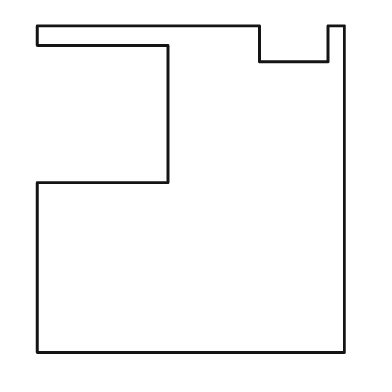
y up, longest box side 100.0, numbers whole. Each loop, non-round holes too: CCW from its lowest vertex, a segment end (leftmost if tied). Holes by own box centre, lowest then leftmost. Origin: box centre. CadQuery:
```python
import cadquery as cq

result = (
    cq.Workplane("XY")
    .moveTo(-47.0, -50.0)
    .lineTo(47.0, -50.0)
    .lineTo(47.0, 50.0)
    .lineTo(42.0, 50.0)
    .lineTo(42.0, 39.0)
    .lineTo(21.0, 39.0)
    .lineTo(21.0, 50.0)
    .lineTo(-47.0, 50.0)
    .lineTo(-47.0, 44.0)
    .lineTo(-7.0, 44.0)
    .lineTo(-7.0, 2.0)
    .lineTo(-47.0, 2.0)
    .close()
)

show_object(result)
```